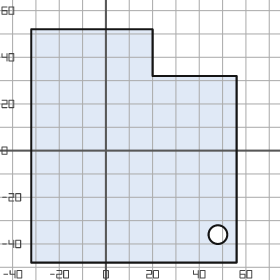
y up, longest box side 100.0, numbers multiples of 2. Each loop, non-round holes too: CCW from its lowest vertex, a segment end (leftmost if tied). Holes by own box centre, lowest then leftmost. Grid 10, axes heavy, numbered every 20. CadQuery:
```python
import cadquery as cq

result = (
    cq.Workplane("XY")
    .moveTo(-32.0, -48.0)
    .lineTo(56.0, -48.0)
    .lineTo(56.0, 32.0)
    .lineTo(20.0, 32.0)
    .lineTo(20.0, 52.0)
    .lineTo(-32.0, 52.0)
    .close()
    .moveTo(48.0, -36.0)
    .circle(4.0)
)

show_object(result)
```